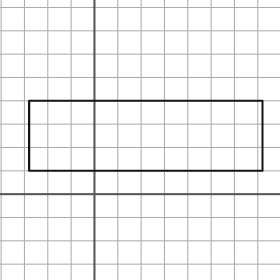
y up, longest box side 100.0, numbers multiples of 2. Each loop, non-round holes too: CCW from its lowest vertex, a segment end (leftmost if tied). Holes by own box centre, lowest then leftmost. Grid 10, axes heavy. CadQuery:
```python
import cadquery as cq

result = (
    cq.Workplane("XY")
    .moveTo(-28.0, 10.0)
    .lineTo(72.0, 10.0)
    .lineTo(72.0, 40.0)
    .lineTo(-28.0, 40.0)
    .close()
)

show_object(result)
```